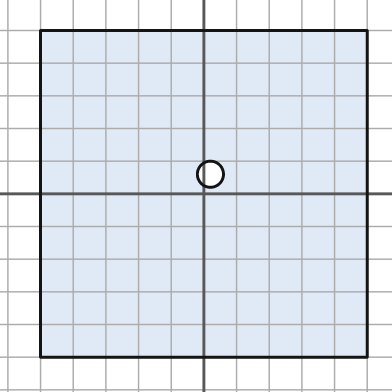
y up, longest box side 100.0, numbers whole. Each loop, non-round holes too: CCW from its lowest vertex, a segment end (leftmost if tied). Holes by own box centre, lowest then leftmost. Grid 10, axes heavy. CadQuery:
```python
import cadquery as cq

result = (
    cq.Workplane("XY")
    .moveTo(-50.0, -50.0)
    .lineTo(50.0, -50.0)
    .lineTo(50.0, 50.0)
    .lineTo(-50.0, 50.0)
    .close()
    .moveTo(2.0, 6.0)
    .circle(4.0)
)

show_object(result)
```